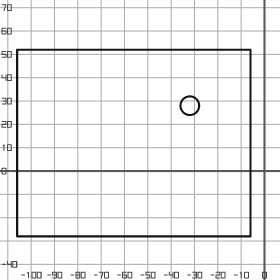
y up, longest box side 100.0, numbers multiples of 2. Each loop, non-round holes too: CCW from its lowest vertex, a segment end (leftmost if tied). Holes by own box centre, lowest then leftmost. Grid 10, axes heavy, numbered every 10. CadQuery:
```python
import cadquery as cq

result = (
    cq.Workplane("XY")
    .moveTo(-106.0, -28.0)
    .lineTo(-6.0, -28.0)
    .lineTo(-6.0, 52.0)
    .lineTo(-106.0, 52.0)
    .close()
    .moveTo(-32.0, 28.0)
    .circle(4.0)
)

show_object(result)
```